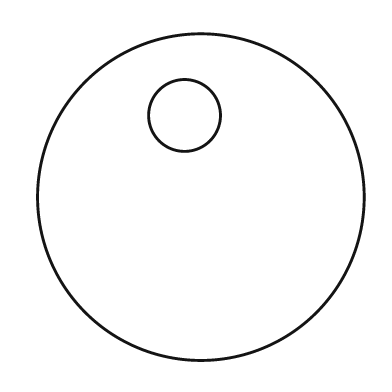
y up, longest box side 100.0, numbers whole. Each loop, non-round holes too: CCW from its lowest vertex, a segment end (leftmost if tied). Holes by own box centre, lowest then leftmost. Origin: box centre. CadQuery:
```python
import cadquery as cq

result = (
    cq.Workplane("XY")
    .moveTo(0.0, 0.0)
    .circle(50.0)
    .moveTo(-5.0, 25.0)
    .circle(11.0)
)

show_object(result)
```